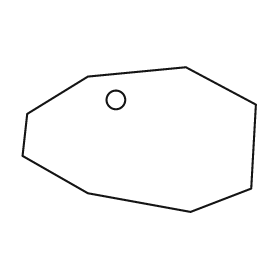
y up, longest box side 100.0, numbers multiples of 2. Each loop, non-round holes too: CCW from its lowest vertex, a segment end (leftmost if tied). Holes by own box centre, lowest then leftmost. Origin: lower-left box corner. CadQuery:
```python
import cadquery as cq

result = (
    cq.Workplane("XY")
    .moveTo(72.0, 0.0)
    .lineTo(98.0, 10.0)
    .lineTo(100.0, 46.0)
    .lineTo(70.0, 62.0)
    .lineTo(28.0, 58.0)
    .lineTo(2.0, 42.0)
    .lineTo(0.0, 24.0)
    .lineTo(28.0, 8.0)
    .close()
    .moveTo(40.0, 48.0)
    .circle(4.0)
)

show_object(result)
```